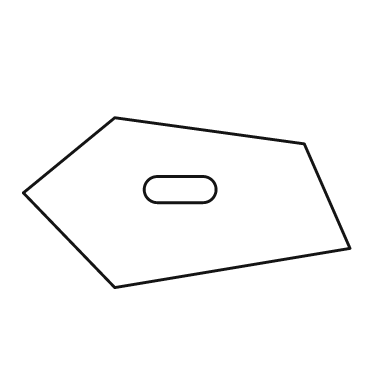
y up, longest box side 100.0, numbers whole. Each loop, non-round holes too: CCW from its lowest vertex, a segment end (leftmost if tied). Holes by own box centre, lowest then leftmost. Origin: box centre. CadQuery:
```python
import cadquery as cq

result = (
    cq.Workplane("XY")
    .moveTo(-22.0, -26.0)
    .lineTo(50.0, -14.0)
    .lineTo(36.0, 18.0)
    .lineTo(-22.0, 26.0)
    .lineTo(-50.0, 3.0)
    .close()
    .moveTo(-9.0, 0.0)
    .lineTo(5.0, 0.0)
    .threePointArc((9.0, 4.0), (5.0, 8.0))
    .lineTo(-9.0, 8.0)
    .threePointArc((-13.0, 4.0), (-9.0, 0.0))
    .close()
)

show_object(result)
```